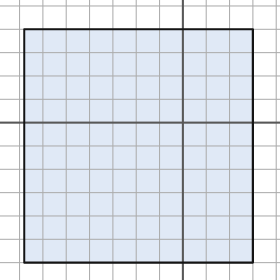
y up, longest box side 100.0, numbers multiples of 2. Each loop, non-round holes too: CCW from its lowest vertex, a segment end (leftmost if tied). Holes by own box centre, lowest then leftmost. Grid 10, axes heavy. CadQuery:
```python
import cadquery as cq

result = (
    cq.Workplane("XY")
    .moveTo(-68.0, -60.0)
    .lineTo(30.0, -60.0)
    .lineTo(30.0, 40.0)
    .lineTo(-68.0, 40.0)
    .close()
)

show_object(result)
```